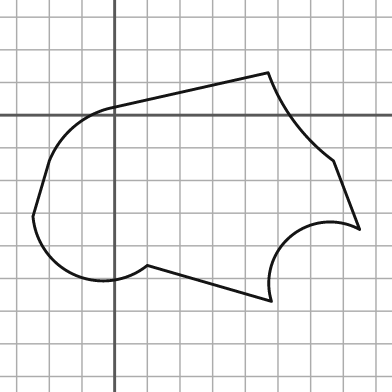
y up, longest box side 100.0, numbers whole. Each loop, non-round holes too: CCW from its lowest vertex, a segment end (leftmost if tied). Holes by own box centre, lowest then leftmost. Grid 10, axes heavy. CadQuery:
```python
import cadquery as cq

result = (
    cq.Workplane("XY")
    .moveTo(48.0, -57.0)
    .threePointArc((54.0, -37.0), (75.0, -35.0))
    .lineTo(67.0, -14.0)
    .threePointArc((55.0, -2.0), (47.0, 13.0))
    .lineTo(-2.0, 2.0)
    .threePointArc((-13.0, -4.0), (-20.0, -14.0))
    .lineTo(-25.0, -31.0)
    .threePointArc((-12.0, -49.0), (10.0, -46.0))
    .close()
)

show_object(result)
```